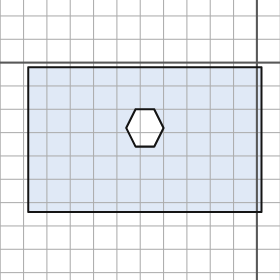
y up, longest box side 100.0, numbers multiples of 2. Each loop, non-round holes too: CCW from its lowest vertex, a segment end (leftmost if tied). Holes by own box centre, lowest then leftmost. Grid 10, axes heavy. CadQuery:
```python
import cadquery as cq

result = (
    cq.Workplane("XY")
    .moveTo(-98.0, -64.0)
    .lineTo(2.0, -64.0)
    .lineTo(2.0, -2.0)
    .lineTo(-98.0, -2.0)
    .close()
    .moveTo(-52.0, -36.0)
    .lineTo(-44.0, -36.0)
    .lineTo(-40.0, -28.0)
    .lineTo(-44.0, -20.0)
    .lineTo(-52.0, -20.0)
    .lineTo(-56.0, -28.0)
    .close()
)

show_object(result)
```